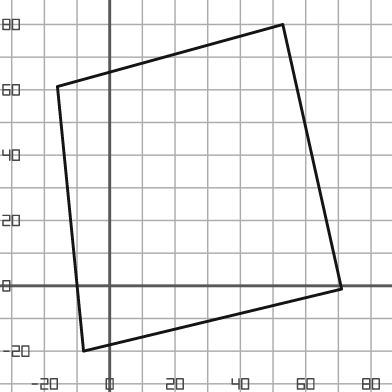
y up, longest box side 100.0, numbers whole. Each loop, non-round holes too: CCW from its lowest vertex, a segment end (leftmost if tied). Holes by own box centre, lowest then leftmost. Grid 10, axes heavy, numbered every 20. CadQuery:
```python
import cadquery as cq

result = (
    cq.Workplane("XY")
    .moveTo(-8.0, -20.0)
    .lineTo(71.0, -1.0)
    .lineTo(53.0, 80.0)
    .lineTo(-16.0, 61.0)
    .close()
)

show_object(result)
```